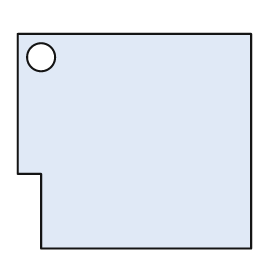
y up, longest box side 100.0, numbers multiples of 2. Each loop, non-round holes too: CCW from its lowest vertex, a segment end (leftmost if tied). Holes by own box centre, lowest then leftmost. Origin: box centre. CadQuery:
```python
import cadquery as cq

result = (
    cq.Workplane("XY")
    .moveTo(-40.0, -46.0)
    .lineTo(50.0, -46.0)
    .lineTo(50.0, 46.0)
    .lineTo(-50.0, 46.0)
    .lineTo(-50.0, -14.0)
    .lineTo(-40.0, -14.0)
    .close()
    .moveTo(-40.0, 36.0)
    .circle(6.0)
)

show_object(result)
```